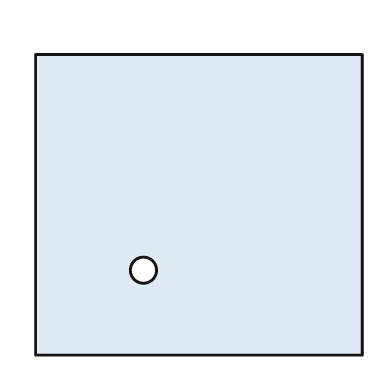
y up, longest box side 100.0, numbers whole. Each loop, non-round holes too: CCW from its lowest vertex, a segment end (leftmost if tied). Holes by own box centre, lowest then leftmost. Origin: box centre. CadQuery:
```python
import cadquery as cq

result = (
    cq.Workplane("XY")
    .moveTo(-50.0, -46.0)
    .lineTo(50.0, -46.0)
    .lineTo(50.0, 46.0)
    .lineTo(-50.0, 46.0)
    .close()
    .moveTo(-17.0, -20.0)
    .circle(4.0)
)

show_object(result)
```